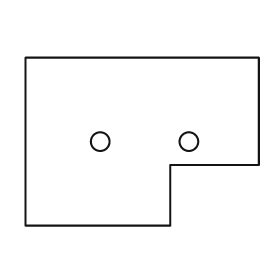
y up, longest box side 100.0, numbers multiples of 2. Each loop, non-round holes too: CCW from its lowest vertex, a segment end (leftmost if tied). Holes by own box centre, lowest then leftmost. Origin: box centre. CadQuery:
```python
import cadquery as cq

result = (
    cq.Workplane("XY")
    .moveTo(-50.0, -36.0)
    .lineTo(12.0, -36.0)
    .lineTo(12.0, -10.0)
    .lineTo(50.0, -10.0)
    .lineTo(50.0, 36.0)
    .lineTo(-50.0, 36.0)
    .close()
    .moveTo(-18.0, 0.0)
    .circle(4.0)
    .moveTo(20.0, 0.0)
    .circle(4.0)
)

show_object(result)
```